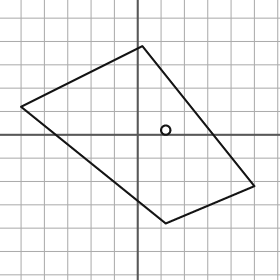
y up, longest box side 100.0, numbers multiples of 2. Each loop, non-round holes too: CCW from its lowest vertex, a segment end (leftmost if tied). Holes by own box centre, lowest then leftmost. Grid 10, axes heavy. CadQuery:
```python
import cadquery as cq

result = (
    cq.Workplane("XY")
    .moveTo(12.0, -38.0)
    .lineTo(50.0, -22.0)
    .lineTo(2.0, 38.0)
    .lineTo(-50.0, 12.0)
    .close()
    .moveTo(12.0, 2.0)
    .circle(2.0)
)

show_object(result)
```